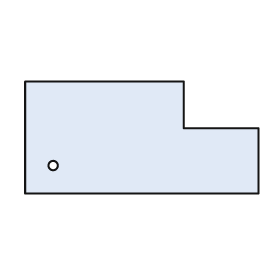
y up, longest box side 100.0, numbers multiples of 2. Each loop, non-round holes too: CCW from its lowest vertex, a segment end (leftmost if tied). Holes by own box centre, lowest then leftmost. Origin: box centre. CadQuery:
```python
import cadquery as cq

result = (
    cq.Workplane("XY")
    .moveTo(-50.0, -24.0)
    .lineTo(50.0, -24.0)
    .lineTo(50.0, 4.0)
    .lineTo(18.0, 4.0)
    .lineTo(18.0, 24.0)
    .lineTo(-50.0, 24.0)
    .close()
    .moveTo(-38.0, -12.0)
    .circle(2.0)
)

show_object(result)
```